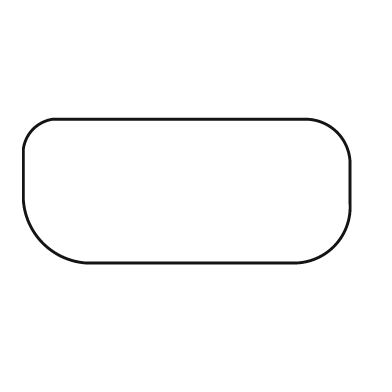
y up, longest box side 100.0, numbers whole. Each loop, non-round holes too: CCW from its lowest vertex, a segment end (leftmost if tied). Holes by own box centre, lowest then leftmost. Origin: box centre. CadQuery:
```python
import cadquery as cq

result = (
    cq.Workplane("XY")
    .moveTo(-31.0, -22.0)
    .lineTo(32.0, -22.0)
    .threePointArc((45.0, -17.0), (50.0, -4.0))
    .lineTo(50.0, 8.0)
    .threePointArc((46.0, 18.0), (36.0, 22.0))
    .lineTo(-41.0, 22.0)
    .threePointArc((-47.0, 19.0), (-50.0, 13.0))
    .lineTo(-50.0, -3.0)
    .threePointArc((-44.0, -16.0), (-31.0, -22.0))
    .close()
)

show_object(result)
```